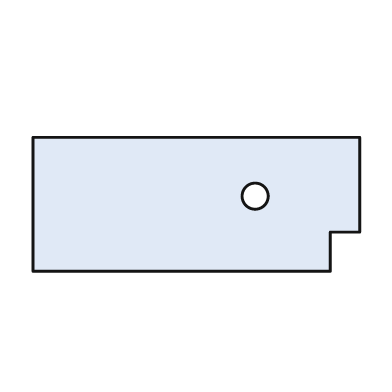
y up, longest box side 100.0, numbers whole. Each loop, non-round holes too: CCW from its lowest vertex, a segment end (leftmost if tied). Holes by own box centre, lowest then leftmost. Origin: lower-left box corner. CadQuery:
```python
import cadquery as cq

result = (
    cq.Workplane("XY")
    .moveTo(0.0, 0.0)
    .lineTo(91.0, 0.0)
    .lineTo(91.0, 12.0)
    .lineTo(100.0, 12.0)
    .lineTo(100.0, 41.0)
    .lineTo(0.0, 41.0)
    .close()
    .moveTo(68.0, 23.0)
    .circle(4.0)
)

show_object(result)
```